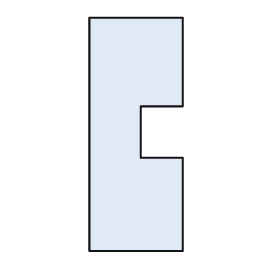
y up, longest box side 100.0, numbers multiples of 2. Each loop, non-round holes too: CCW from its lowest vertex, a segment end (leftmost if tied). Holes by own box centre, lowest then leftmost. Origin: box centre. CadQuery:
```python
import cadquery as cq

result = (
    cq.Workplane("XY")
    .moveTo(-20.0, -50.0)
    .lineTo(20.0, -50.0)
    .lineTo(20.0, -10.0)
    .lineTo(2.0, -10.0)
    .lineTo(2.0, 12.0)
    .lineTo(20.0, 12.0)
    .lineTo(20.0, 50.0)
    .lineTo(-20.0, 50.0)
    .close()
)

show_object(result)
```